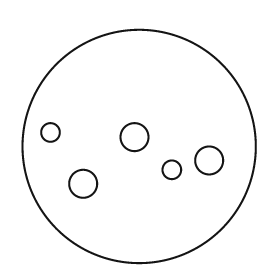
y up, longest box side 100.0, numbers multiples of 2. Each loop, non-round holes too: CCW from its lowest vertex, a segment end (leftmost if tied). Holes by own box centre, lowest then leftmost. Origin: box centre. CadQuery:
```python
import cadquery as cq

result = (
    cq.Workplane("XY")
    .moveTo(0.0, 0.0)
    .circle(50.0)
    .moveTo(-24.0, -16.0)
    .circle(6.0)
    .moveTo(14.0, -10.0)
    .circle(4.0)
    .moveTo(30.0, -6.0)
    .circle(6.0)
    .moveTo(-2.0, 4.0)
    .circle(6.0)
    .moveTo(-38.0, 6.0)
    .circle(4.0)
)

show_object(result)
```